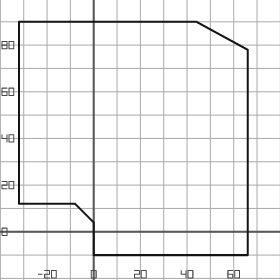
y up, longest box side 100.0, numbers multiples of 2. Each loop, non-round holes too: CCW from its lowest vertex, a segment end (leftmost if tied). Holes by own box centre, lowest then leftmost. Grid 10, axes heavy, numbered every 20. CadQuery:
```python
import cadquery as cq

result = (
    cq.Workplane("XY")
    .moveTo(0.0, -10.0)
    .lineTo(66.0, -10.0)
    .lineTo(66.0, 78.0)
    .lineTo(44.0, 90.0)
    .lineTo(-32.0, 90.0)
    .lineTo(-32.0, 12.0)
    .lineTo(-8.0, 12.0)
    .lineTo(0.0, 4.0)
    .close()
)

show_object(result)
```